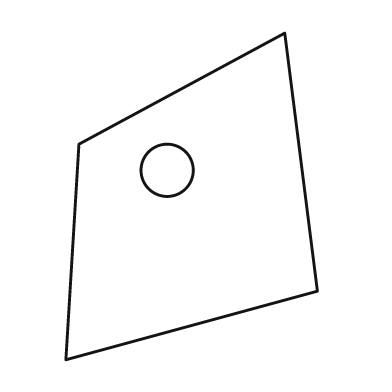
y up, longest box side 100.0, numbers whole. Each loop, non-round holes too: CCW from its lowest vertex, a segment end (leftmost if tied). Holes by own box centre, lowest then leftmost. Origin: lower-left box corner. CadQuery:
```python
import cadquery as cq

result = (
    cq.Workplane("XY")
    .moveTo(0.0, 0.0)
    .lineTo(77.0, 21.0)
    .lineTo(67.0, 100.0)
    .lineTo(4.0, 66.0)
    .close()
    .moveTo(31.0, 58.0)
    .circle(8.0)
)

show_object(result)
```